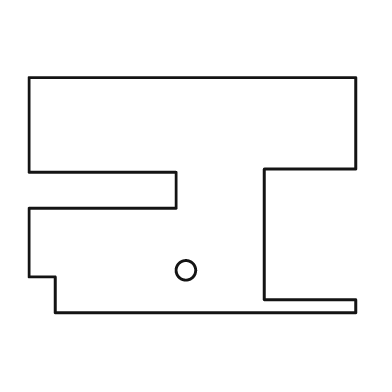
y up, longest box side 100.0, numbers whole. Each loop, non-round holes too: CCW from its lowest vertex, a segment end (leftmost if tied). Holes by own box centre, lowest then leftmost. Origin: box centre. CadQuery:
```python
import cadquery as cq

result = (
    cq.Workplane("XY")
    .moveTo(-42.0, -36.0)
    .lineTo(50.0, -36.0)
    .lineTo(50.0, -32.0)
    .lineTo(22.0, -32.0)
    .lineTo(22.0, 8.0)
    .lineTo(50.0, 8.0)
    .lineTo(50.0, 36.0)
    .lineTo(-50.0, 36.0)
    .lineTo(-50.0, 7.0)
    .lineTo(-5.0, 7.0)
    .lineTo(-5.0, -4.0)
    .lineTo(-50.0, -4.0)
    .lineTo(-50.0, -25.0)
    .lineTo(-42.0, -25.0)
    .close()
    .moveTo(-2.0, -23.0)
    .circle(3.0)
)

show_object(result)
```